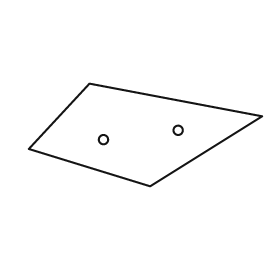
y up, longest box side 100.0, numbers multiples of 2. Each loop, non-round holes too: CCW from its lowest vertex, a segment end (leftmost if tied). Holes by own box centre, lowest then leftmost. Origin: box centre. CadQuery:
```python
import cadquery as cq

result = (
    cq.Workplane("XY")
    .moveTo(2.0, -22.0)
    .lineTo(50.0, 8.0)
    .lineTo(-24.0, 22.0)
    .lineTo(-50.0, -6.0)
    .close()
    .moveTo(-18.0, -2.0)
    .circle(2.0)
    .moveTo(14.0, 2.0)
    .circle(2.0)
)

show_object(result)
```